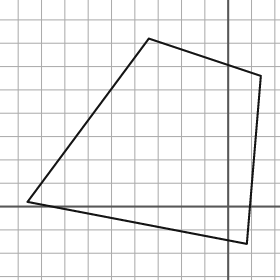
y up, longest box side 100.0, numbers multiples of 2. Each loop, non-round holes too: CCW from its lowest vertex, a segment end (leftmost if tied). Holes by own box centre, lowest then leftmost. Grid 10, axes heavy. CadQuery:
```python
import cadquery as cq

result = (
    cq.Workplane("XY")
    .moveTo(8.0, -16.0)
    .lineTo(14.0, 56.0)
    .lineTo(-34.0, 72.0)
    .lineTo(-86.0, 2.0)
    .close()
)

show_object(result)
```